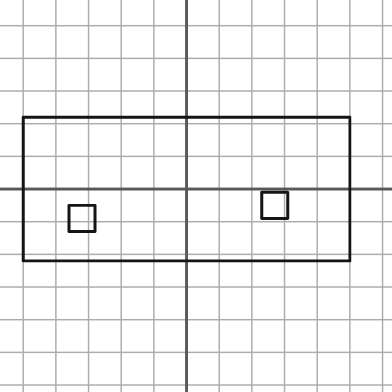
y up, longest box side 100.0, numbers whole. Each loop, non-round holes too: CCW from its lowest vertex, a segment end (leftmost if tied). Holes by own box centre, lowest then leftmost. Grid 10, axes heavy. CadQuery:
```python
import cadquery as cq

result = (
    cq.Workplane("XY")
    .moveTo(-50.0, -22.0)
    .lineTo(50.0, -22.0)
    .lineTo(50.0, 22.0)
    .lineTo(-50.0, 22.0)
    .close()
    .moveTo(-36.0, -13.0)
    .lineTo(-28.0, -13.0)
    .lineTo(-28.0, -5.0)
    .lineTo(-36.0, -5.0)
    .close()
    .moveTo(23.0, -9.0)
    .lineTo(31.0, -9.0)
    .lineTo(31.0, -1.0)
    .lineTo(23.0, -1.0)
    .close()
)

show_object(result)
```